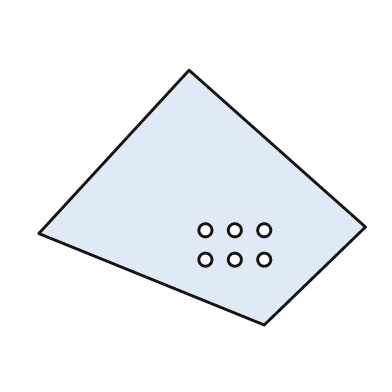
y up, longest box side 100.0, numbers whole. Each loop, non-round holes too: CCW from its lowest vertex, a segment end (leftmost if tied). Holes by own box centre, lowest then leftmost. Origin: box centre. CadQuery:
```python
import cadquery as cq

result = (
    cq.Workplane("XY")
    .moveTo(19.0, -39.0)
    .lineTo(50.0, -9.0)
    .lineTo(-4.0, 39.0)
    .lineTo(-50.0, -11.0)
    .close()
    .moveTo(1.0, -19.0)
    .circle(2.0)
    .moveTo(10.0, -19.0)
    .circle(2.0)
    .moveTo(19.0, -19.0)
    .circle(2.0)
    .moveTo(1.0, -10.0)
    .circle(2.0)
    .moveTo(10.0, -10.0)
    .circle(2.0)
    .moveTo(19.0, -10.0)
    .circle(2.0)
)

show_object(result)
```